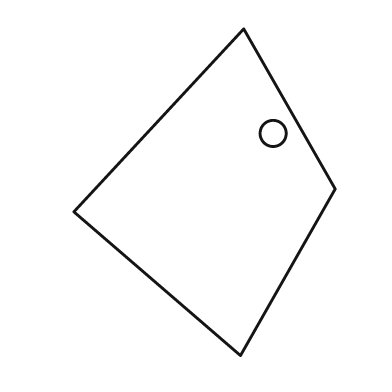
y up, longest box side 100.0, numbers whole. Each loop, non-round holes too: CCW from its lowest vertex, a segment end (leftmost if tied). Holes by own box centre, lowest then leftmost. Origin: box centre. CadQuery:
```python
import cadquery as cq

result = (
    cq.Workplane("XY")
    .moveTo(11.0, -50.0)
    .lineTo(40.0, 1.0)
    .lineTo(12.0, 50.0)
    .lineTo(-40.0, -6.0)
    .close()
    .moveTo(21.0, 18.0)
    .circle(4.0)
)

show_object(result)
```